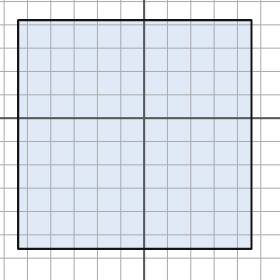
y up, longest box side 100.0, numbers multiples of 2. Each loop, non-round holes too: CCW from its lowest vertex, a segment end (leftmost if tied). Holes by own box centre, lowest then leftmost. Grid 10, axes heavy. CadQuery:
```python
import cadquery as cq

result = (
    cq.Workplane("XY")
    .moveTo(-54.0, -56.0)
    .lineTo(46.0, -56.0)
    .lineTo(46.0, 42.0)
    .lineTo(-54.0, 42.0)
    .close()
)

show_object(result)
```